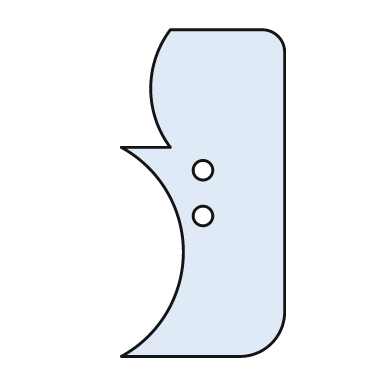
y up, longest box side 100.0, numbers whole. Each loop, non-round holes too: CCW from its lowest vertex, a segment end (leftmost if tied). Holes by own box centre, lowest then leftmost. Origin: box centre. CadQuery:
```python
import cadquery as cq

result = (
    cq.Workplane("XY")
    .moveTo(-25.0, -50.0)
    .lineTo(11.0, -50.0)
    .threePointArc((21.0, -46.0), (25.0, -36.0))
    .lineTo(25.0, 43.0)
    .threePointArc((23.0, 48.0), (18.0, 50.0))
    .lineTo(-10.0, 50.0)
    .threePointArc((-16.0, 32.0), (-10.0, 14.0))
    .lineTo(-25.0, 14.0)
    .threePointArc((-6.0, -18.0), (-25.0, -50.0))
    .close()
    .moveTo(0.0, -7.0)
    .circle(3.0)
    .moveTo(0.0, 7.0)
    .circle(3.0)
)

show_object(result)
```